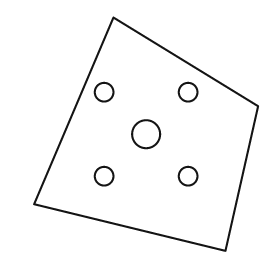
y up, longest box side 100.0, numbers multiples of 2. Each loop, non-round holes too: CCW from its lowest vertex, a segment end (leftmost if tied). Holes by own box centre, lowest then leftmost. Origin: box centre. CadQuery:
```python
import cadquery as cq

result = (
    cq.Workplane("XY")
    .moveTo(34.0, -50.0)
    .lineTo(48.0, 12.0)
    .lineTo(-14.0, 50.0)
    .lineTo(-48.0, -30.0)
    .close()
    .moveTo(-18.0, -18.0)
    .circle(4.0)
    .moveTo(18.0, -18.0)
    .circle(4.0)
    .moveTo(0.0, 0.0)
    .circle(6.0)
    .moveTo(-18.0, 18.0)
    .circle(4.0)
    .moveTo(18.0, 18.0)
    .circle(4.0)
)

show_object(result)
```